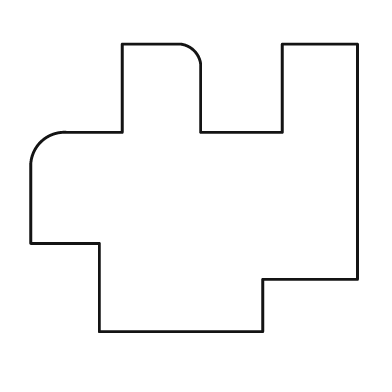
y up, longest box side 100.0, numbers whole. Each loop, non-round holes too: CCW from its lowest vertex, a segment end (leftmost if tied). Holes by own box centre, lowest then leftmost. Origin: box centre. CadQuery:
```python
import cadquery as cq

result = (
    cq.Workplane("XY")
    .moveTo(-29.0, -44.0)
    .lineTo(21.0, -44.0)
    .lineTo(21.0, -28.0)
    .lineTo(50.0, -28.0)
    .lineTo(50.0, 44.0)
    .lineTo(27.0, 44.0)
    .lineTo(27.0, 17.0)
    .lineTo(2.0, 17.0)
    .lineTo(2.0, 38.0)
    .threePointArc((0.0, 42.0), (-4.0, 44.0))
    .lineTo(-22.0, 44.0)
    .lineTo(-22.0, 17.0)
    .lineTo(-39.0, 17.0)
    .threePointArc((-47.0, 14.0), (-50.0, 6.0))
    .lineTo(-50.0, -17.0)
    .lineTo(-29.0, -17.0)
    .close()
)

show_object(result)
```